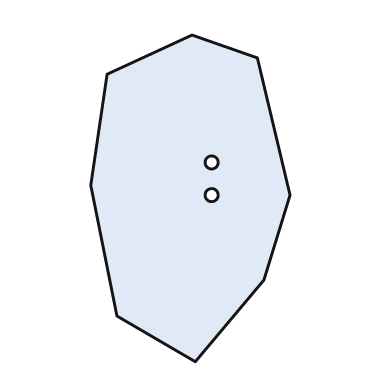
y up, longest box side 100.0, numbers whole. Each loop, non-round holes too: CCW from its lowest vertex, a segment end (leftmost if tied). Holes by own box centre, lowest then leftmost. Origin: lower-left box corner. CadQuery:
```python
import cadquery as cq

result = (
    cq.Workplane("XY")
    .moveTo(32.0, 0.0)
    .lineTo(53.0, 25.0)
    .lineTo(61.0, 51.0)
    .lineTo(51.0, 93.0)
    .lineTo(31.0, 100.0)
    .lineTo(5.0, 88.0)
    .lineTo(0.0, 54.0)
    .lineTo(8.0, 14.0)
    .close()
    .moveTo(37.0, 51.0)
    .circle(2.0)
    .moveTo(37.0, 61.0)
    .circle(2.0)
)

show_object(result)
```